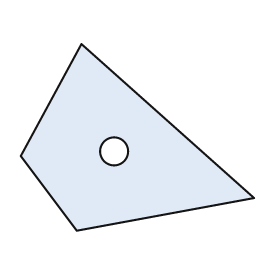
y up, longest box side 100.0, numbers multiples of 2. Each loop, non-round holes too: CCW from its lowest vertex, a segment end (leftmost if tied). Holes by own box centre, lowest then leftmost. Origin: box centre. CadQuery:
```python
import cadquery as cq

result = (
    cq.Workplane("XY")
    .moveTo(-26.0, -40.0)
    .lineTo(50.0, -26.0)
    .lineTo(-24.0, 40.0)
    .lineTo(-50.0, -8.0)
    .close()
    .moveTo(-10.0, -6.0)
    .circle(6.0)
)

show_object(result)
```